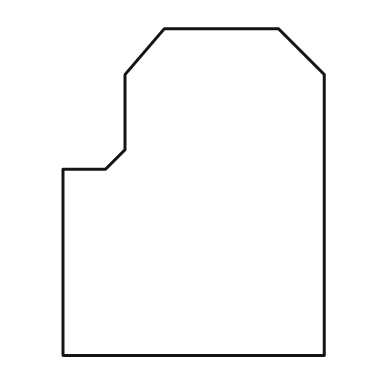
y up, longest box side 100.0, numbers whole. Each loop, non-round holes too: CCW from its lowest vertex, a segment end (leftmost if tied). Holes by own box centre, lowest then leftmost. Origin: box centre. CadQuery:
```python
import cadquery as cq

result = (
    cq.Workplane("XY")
    .moveTo(-40.0, -50.0)
    .lineTo(40.0, -50.0)
    .lineTo(40.0, 36.0)
    .lineTo(26.0, 50.0)
    .lineTo(-9.0, 50.0)
    .lineTo(-21.0, 36.0)
    .lineTo(-21.0, 13.0)
    .lineTo(-27.0, 7.0)
    .lineTo(-40.0, 7.0)
    .close()
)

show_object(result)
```